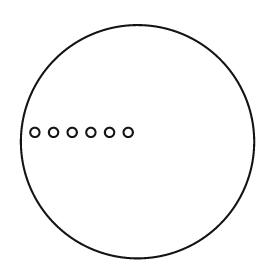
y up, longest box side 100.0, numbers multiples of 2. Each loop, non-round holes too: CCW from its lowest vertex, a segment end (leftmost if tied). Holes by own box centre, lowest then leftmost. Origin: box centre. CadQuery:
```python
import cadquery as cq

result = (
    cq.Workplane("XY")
    .moveTo(0.0, 0.0)
    .circle(50.0)
    .moveTo(-44.0, 4.0)
    .circle(2.0)
    .moveTo(-36.0, 4.0)
    .circle(2.0)
    .moveTo(-28.0, 4.0)
    .circle(2.0)
    .moveTo(-20.0, 4.0)
    .circle(2.0)
    .moveTo(-12.0, 4.0)
    .circle(2.0)
    .moveTo(-4.0, 4.0)
    .circle(2.0)
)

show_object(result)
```